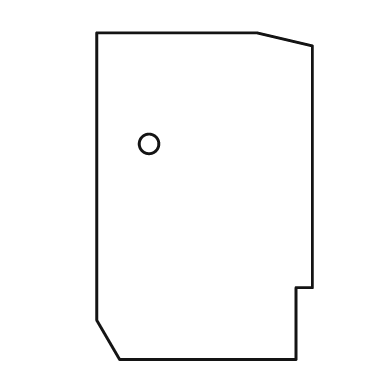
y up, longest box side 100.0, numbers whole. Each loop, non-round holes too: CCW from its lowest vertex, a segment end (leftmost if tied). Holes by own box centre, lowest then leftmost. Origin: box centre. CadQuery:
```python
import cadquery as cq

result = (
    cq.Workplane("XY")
    .moveTo(-26.0, -50.0)
    .lineTo(28.0, -50.0)
    .lineTo(28.0, -28.0)
    .lineTo(33.0, -28.0)
    .lineTo(33.0, 46.0)
    .lineTo(16.0, 50.0)
    .lineTo(-33.0, 50.0)
    .lineTo(-33.0, -38.0)
    .close()
    .moveTo(-17.0, 16.0)
    .circle(3.0)
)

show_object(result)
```